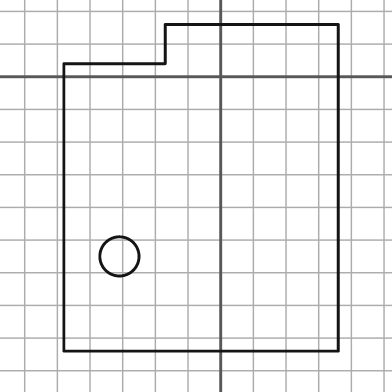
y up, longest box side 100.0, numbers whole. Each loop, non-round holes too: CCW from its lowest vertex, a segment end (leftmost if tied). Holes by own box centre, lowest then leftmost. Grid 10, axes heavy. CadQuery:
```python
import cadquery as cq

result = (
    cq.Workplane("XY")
    .moveTo(-48.0, -84.0)
    .lineTo(36.0, -84.0)
    .lineTo(36.0, 16.0)
    .lineTo(-17.0, 16.0)
    .lineTo(-17.0, 4.0)
    .lineTo(-48.0, 4.0)
    .close()
    .moveTo(-31.0, -55.0)
    .circle(6.0)
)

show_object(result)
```